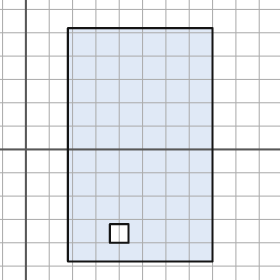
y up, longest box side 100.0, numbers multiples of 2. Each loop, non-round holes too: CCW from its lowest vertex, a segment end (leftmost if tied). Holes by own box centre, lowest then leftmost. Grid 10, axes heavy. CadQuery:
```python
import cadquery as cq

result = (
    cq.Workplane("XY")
    .moveTo(18.0, -48.0)
    .lineTo(80.0, -48.0)
    .lineTo(80.0, 52.0)
    .lineTo(18.0, 52.0)
    .close()
    .moveTo(36.0, -40.0)
    .lineTo(44.0, -40.0)
    .lineTo(44.0, -32.0)
    .lineTo(36.0, -32.0)
    .close()
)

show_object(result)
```